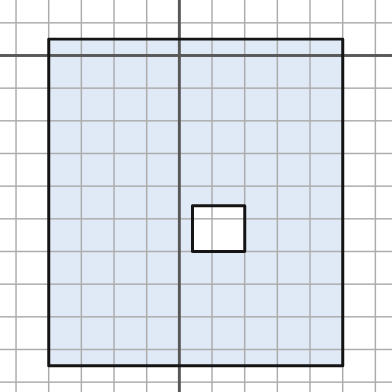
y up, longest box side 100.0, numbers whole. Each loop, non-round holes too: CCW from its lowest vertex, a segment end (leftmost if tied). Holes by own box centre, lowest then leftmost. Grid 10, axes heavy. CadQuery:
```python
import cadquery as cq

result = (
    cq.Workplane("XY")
    .moveTo(-40.0, -95.0)
    .lineTo(50.0, -95.0)
    .lineTo(50.0, 5.0)
    .lineTo(-40.0, 5.0)
    .close()
    .moveTo(4.0, -60.0)
    .lineTo(20.0, -60.0)
    .lineTo(20.0, -46.0)
    .lineTo(4.0, -46.0)
    .close()
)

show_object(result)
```